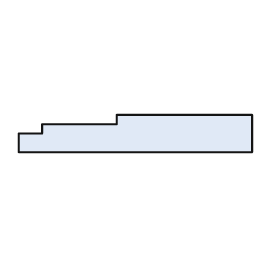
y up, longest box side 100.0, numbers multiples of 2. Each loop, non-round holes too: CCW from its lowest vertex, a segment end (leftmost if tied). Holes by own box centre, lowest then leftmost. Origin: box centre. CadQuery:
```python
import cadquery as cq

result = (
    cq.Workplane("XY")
    .moveTo(-50.0, -8.0)
    .lineTo(50.0, -8.0)
    .lineTo(50.0, 8.0)
    .lineTo(-8.0, 8.0)
    .lineTo(-8.0, 4.0)
    .lineTo(-40.0, 4.0)
    .lineTo(-40.0, 0.0)
    .lineTo(-50.0, 0.0)
    .close()
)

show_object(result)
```